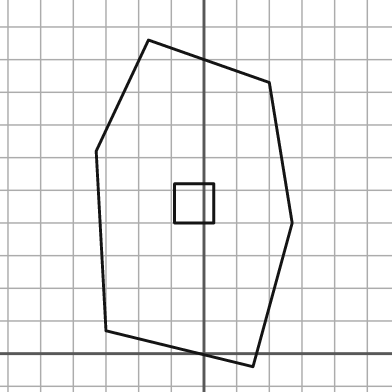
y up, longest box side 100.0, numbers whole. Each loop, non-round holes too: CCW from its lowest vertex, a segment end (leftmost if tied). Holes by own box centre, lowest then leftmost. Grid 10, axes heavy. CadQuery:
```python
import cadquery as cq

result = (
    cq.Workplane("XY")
    .moveTo(15.0, -4.0)
    .lineTo(27.0, 40.0)
    .lineTo(20.0, 83.0)
    .lineTo(-17.0, 96.0)
    .lineTo(-33.0, 62.0)
    .lineTo(-30.0, 7.0)
    .close()
    .moveTo(-9.0, 40.0)
    .lineTo(3.0, 40.0)
    .lineTo(3.0, 52.0)
    .lineTo(-9.0, 52.0)
    .close()
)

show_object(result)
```